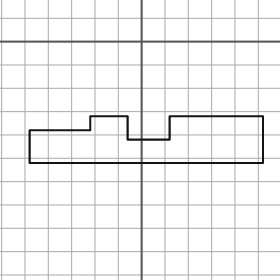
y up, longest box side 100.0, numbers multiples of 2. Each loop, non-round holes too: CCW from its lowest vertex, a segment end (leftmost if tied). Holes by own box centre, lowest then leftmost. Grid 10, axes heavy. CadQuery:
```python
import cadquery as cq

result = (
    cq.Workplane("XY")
    .moveTo(-48.0, -52.0)
    .lineTo(52.0, -52.0)
    .lineTo(52.0, -32.0)
    .lineTo(12.0, -32.0)
    .lineTo(12.0, -42.0)
    .lineTo(-6.0, -42.0)
    .lineTo(-6.0, -32.0)
    .lineTo(-22.0, -32.0)
    .lineTo(-22.0, -38.0)
    .lineTo(-48.0, -38.0)
    .close()
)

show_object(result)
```